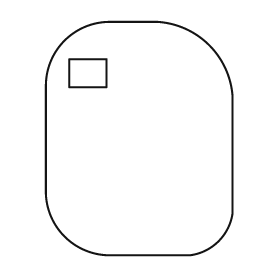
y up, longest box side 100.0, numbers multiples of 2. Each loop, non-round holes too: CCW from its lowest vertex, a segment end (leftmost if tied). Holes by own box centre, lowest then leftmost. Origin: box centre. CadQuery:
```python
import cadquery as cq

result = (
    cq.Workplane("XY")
    .moveTo(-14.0, -50.0)
    .lineTo(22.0, -50.0)
    .threePointArc((34.0, -44.0), (40.0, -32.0))
    .lineTo(40.0, 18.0)
    .threePointArc((30.0, 40.0), (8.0, 50.0))
    .lineTo(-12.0, 50.0)
    .threePointArc((-32.0, 42.0), (-40.0, 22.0))
    .lineTo(-40.0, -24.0)
    .threePointArc((-32.0, -42.0), (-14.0, -50.0))
    .close()
    .moveTo(-30.0, 22.0)
    .lineTo(-14.0, 22.0)
    .lineTo(-14.0, 34.0)
    .lineTo(-30.0, 34.0)
    .close()
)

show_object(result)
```